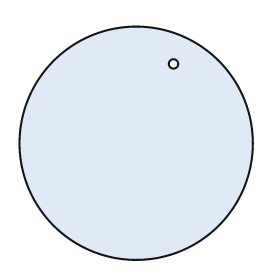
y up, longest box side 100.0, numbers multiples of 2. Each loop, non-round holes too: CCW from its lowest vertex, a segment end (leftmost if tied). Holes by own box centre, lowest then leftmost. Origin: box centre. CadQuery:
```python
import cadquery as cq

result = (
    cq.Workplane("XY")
    .moveTo(0.0, 0.0)
    .circle(50.0)
    .moveTo(16.0, 34.0)
    .circle(2.0)
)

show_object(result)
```